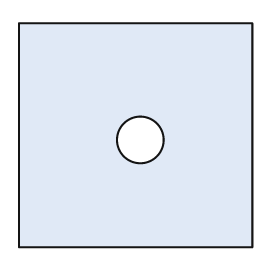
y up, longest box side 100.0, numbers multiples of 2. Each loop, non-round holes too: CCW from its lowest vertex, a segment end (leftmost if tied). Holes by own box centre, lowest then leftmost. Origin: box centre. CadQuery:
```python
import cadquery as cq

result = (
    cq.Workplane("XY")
    .moveTo(-50.0, -48.0)
    .lineTo(50.0, -48.0)
    .lineTo(50.0, 48.0)
    .lineTo(-50.0, 48.0)
    .close()
    .moveTo(2.0, -2.0)
    .circle(10.0)
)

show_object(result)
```